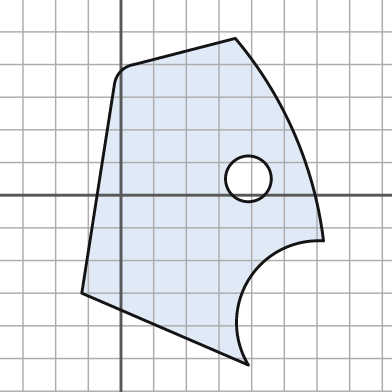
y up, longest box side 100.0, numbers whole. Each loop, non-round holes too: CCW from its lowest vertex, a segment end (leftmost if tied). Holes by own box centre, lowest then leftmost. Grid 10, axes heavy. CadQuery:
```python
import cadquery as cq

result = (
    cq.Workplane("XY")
    .moveTo(39.0, -52.0)
    .threePointArc((39.0, -26.0), (62.0, -14.0))
    .threePointArc((53.0, 19.0), (35.0, 48.0))
    .lineTo(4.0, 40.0)
    .threePointArc((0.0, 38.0), (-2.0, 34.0))
    .lineTo(-12.0, -30.0)
    .close()
    .moveTo(39.0, 5.0)
    .circle(7.0)
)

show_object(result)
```